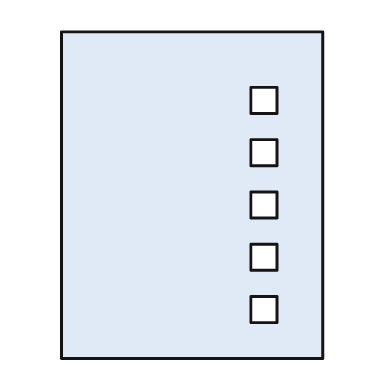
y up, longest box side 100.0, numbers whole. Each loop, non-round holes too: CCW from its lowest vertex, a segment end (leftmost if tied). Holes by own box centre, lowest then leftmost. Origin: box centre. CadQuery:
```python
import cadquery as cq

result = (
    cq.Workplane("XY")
    .moveTo(-40.0, -50.0)
    .lineTo(40.0, -50.0)
    .lineTo(40.0, 50.0)
    .lineTo(-40.0, 50.0)
    .close()
    .moveTo(18.0, -39.0)
    .lineTo(26.0, -39.0)
    .lineTo(26.0, -31.0)
    .lineTo(18.0, -31.0)
    .close()
    .moveTo(18.0, -23.0)
    .lineTo(26.0, -23.0)
    .lineTo(26.0, -15.0)
    .lineTo(18.0, -15.0)
    .close()
    .moveTo(18.0, -7.0)
    .lineTo(26.0, -7.0)
    .lineTo(26.0, 1.0)
    .lineTo(18.0, 1.0)
    .close()
    .moveTo(18.0, 9.0)
    .lineTo(26.0, 9.0)
    .lineTo(26.0, 17.0)
    .lineTo(18.0, 17.0)
    .close()
    .moveTo(18.0, 25.0)
    .lineTo(26.0, 25.0)
    .lineTo(26.0, 33.0)
    .lineTo(18.0, 33.0)
    .close()
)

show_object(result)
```